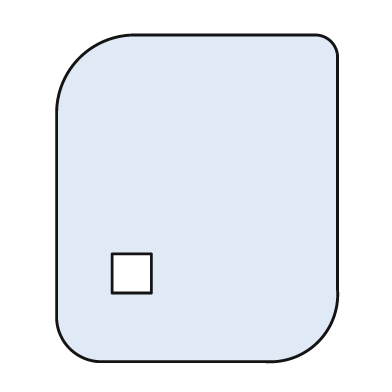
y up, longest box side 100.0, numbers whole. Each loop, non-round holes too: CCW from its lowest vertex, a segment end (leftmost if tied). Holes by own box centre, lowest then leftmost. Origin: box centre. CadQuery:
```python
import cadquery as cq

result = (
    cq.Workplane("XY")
    .moveTo(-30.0, -50.0)
    .lineTo(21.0, -50.0)
    .threePointArc((37.0, -44.0), (43.0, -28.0))
    .lineTo(43.0, 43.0)
    .threePointArc((41.0, 48.0), (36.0, 50.0))
    .lineTo(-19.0, 50.0)
    .threePointArc((-36.0, 43.0), (-43.0, 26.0))
    .lineTo(-43.0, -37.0)
    .threePointArc((-39.0, -46.0), (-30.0, -50.0))
    .close()
    .moveTo(-26.0, -29.0)
    .lineTo(-14.0, -29.0)
    .lineTo(-14.0, -17.0)
    .lineTo(-26.0, -17.0)
    .close()
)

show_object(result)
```